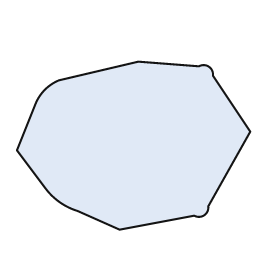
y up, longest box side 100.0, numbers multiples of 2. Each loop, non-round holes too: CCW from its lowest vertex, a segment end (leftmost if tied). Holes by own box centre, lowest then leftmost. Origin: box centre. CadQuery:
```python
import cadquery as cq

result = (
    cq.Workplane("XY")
    .moveTo(-6.0, -36.0)
    .lineTo(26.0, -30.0)
    .threePointArc((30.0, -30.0), (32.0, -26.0))
    .lineTo(50.0, 6.0)
    .lineTo(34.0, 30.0)
    .threePointArc((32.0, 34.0), (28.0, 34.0))
    .lineTo(2.0, 36.0)
    .lineTo(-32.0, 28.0)
    .threePointArc((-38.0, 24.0), (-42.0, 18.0))
    .lineTo(-50.0, -2.0)
    .lineTo(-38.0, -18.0)
    .threePointArc((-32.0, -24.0), (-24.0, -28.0))
    .close()
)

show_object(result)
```